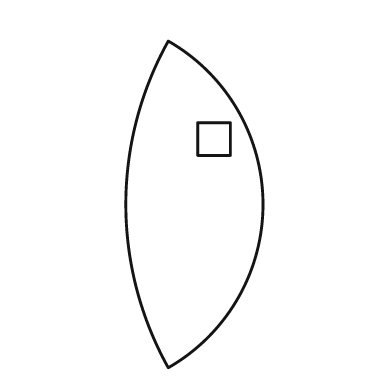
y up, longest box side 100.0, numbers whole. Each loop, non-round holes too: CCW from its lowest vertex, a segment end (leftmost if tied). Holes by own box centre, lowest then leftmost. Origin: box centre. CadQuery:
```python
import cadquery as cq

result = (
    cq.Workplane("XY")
    .moveTo(-8.0, -50.0)
    .threePointArc((21.0, 0.0), (-8.0, 50.0))
    .threePointArc((-21.0, 0.0), (-8.0, -50.0))
    .close()
    .moveTo(1.0, 15.0)
    .lineTo(11.0, 15.0)
    .lineTo(11.0, 25.0)
    .lineTo(1.0, 25.0)
    .close()
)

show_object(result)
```